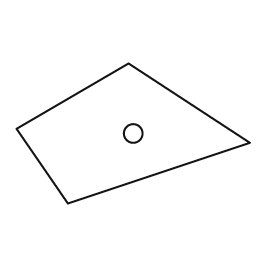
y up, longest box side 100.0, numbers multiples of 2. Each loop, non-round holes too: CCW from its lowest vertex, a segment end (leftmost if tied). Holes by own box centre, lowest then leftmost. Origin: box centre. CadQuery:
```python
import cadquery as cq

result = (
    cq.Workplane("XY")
    .moveTo(-28.0, -30.0)
    .lineTo(50.0, -4.0)
    .lineTo(-2.0, 30.0)
    .lineTo(-50.0, 2.0)
    .close()
    .moveTo(0.0, 0.0)
    .circle(4.0)
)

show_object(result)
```